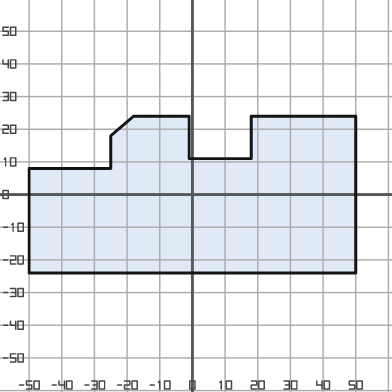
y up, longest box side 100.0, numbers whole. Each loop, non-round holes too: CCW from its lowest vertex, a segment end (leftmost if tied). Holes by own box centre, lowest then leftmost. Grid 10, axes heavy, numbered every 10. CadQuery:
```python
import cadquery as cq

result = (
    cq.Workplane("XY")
    .moveTo(-50.0, -24.0)
    .lineTo(50.0, -24.0)
    .lineTo(50.0, 24.0)
    .lineTo(18.0, 24.0)
    .lineTo(18.0, 11.0)
    .lineTo(-1.0, 11.0)
    .lineTo(-1.0, 24.0)
    .lineTo(-18.0, 24.0)
    .lineTo(-25.0, 18.0)
    .lineTo(-25.0, 8.0)
    .lineTo(-50.0, 8.0)
    .close()
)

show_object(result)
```